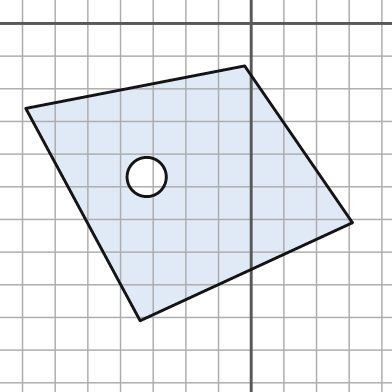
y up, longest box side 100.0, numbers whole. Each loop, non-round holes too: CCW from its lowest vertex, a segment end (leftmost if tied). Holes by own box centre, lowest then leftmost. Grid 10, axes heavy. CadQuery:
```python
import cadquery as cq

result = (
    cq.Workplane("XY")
    .moveTo(-34.0, -91.0)
    .lineTo(31.0, -61.0)
    .lineTo(-2.0, -13.0)
    .lineTo(-69.0, -26.0)
    .close()
    .moveTo(-32.0, -47.0)
    .circle(6.0)
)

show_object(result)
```